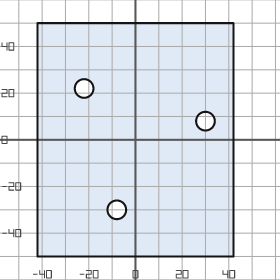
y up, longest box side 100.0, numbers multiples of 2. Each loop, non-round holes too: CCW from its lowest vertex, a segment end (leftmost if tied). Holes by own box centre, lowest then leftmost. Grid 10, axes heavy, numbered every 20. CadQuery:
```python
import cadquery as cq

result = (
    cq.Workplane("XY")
    .moveTo(-42.0, -50.0)
    .lineTo(42.0, -50.0)
    .lineTo(42.0, 50.0)
    .lineTo(-42.0, 50.0)
    .close()
    .moveTo(-8.0, -30.0)
    .circle(4.0)
    .moveTo(30.0, 8.0)
    .circle(4.0)
    .moveTo(-22.0, 22.0)
    .circle(4.0)
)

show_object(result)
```